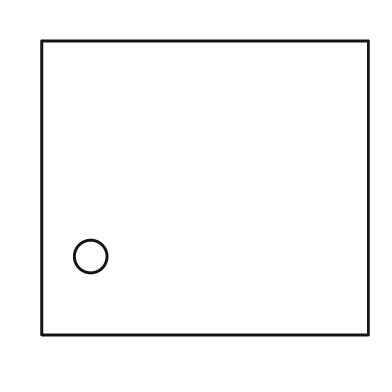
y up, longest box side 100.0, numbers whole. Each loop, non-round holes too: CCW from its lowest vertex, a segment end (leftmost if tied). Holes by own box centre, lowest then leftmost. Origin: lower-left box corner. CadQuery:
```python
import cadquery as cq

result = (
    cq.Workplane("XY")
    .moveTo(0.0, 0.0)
    .lineTo(100.0, 0.0)
    .lineTo(100.0, 90.0)
    .lineTo(0.0, 90.0)
    .close()
    .moveTo(15.0, 24.0)
    .circle(5.0)
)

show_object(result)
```